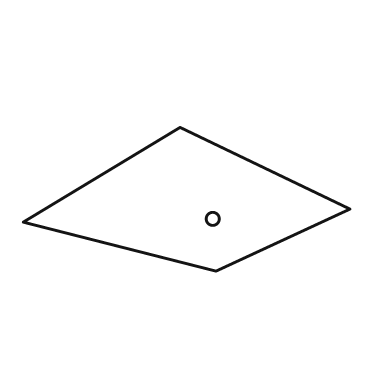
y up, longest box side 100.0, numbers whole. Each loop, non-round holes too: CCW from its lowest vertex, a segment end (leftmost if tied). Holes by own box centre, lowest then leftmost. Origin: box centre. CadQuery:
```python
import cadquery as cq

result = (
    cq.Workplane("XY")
    .moveTo(9.0, -22.0)
    .lineTo(50.0, -3.0)
    .lineTo(-2.0, 22.0)
    .lineTo(-50.0, -7.0)
    .close()
    .moveTo(8.0, -6.0)
    .circle(2.0)
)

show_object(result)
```